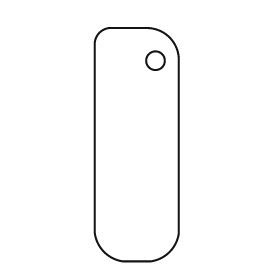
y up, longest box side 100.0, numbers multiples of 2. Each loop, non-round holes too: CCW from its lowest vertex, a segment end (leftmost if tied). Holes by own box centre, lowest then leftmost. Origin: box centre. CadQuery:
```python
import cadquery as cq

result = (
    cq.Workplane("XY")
    .moveTo(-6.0, -50.0)
    .lineTo(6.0, -50.0)
    .threePointArc((14.0, -46.0), (18.0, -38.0))
    .lineTo(18.0, 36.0)
    .threePointArc((14.0, 46.0), (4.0, 50.0))
    .lineTo(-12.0, 50.0)
    .threePointArc((-16.0, 48.0), (-18.0, 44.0))
    .lineTo(-18.0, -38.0)
    .threePointArc((-14.0, -46.0), (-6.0, -50.0))
    .close()
    .moveTo(8.0, 36.0)
    .circle(4.0)
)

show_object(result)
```